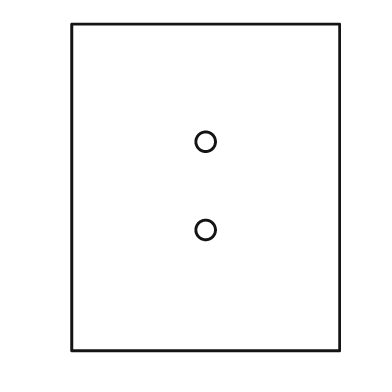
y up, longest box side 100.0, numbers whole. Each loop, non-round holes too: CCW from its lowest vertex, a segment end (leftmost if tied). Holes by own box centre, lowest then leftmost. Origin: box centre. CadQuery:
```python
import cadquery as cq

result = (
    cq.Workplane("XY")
    .moveTo(-41.0, -50.0)
    .lineTo(41.0, -50.0)
    .lineTo(41.0, 50.0)
    .lineTo(-41.0, 50.0)
    .close()
    .moveTo(0.0, -13.0)
    .circle(3.0)
    .moveTo(0.0, 14.0)
    .circle(3.0)
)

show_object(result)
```